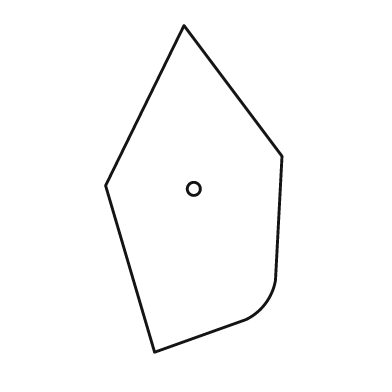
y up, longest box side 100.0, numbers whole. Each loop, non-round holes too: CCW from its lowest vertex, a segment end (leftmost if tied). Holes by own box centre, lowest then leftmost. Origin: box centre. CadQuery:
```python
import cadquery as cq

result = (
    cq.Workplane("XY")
    .moveTo(-12.0, -50.0)
    .lineTo(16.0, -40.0)
    .threePointArc((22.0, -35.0), (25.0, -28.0))
    .lineTo(27.0, 10.0)
    .lineTo(-3.0, 50.0)
    .lineTo(-27.0, 1.0)
    .close()
    .moveTo(0.0, 0.0)
    .circle(2.0)
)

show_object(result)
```